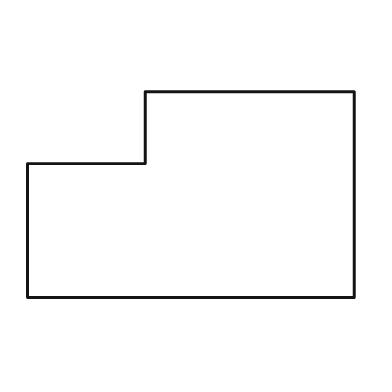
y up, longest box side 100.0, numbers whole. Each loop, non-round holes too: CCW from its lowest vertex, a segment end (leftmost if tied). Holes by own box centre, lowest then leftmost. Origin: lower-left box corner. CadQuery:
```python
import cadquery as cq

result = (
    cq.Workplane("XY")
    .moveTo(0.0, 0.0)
    .lineTo(100.0, 0.0)
    .lineTo(100.0, 63.0)
    .lineTo(36.0, 63.0)
    .lineTo(36.0, 41.0)
    .lineTo(0.0, 41.0)
    .close()
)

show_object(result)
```